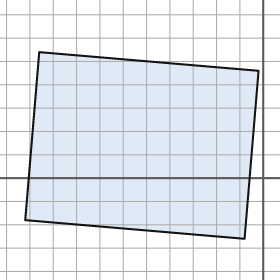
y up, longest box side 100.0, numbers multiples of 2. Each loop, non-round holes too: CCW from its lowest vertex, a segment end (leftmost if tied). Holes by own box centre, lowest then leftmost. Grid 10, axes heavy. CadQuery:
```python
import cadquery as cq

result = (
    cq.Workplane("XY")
    .moveTo(-8.0, -26.0)
    .lineTo(-2.0, 46.0)
    .lineTo(-96.0, 54.0)
    .lineTo(-102.0, -18.0)
    .close()
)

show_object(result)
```